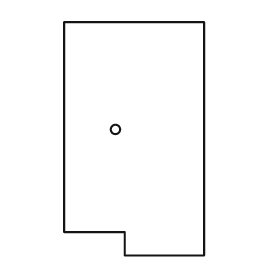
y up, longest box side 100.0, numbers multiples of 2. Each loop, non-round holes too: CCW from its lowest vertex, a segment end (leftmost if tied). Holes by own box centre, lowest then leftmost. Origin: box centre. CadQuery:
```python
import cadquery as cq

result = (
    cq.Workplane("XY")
    .moveTo(-4.0, -50.0)
    .lineTo(30.0, -50.0)
    .lineTo(30.0, 50.0)
    .lineTo(-30.0, 50.0)
    .lineTo(-30.0, -40.0)
    .lineTo(-4.0, -40.0)
    .close()
    .moveTo(-8.0, 4.0)
    .circle(2.0)
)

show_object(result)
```